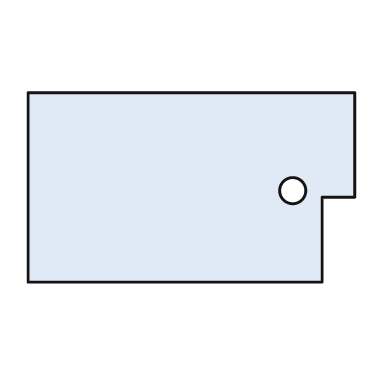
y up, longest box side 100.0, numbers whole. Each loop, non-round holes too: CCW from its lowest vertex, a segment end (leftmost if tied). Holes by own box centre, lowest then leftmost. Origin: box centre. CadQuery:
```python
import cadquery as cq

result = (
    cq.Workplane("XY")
    .moveTo(-50.0, -29.0)
    .lineTo(40.0, -29.0)
    .lineTo(40.0, -3.0)
    .lineTo(50.0, -3.0)
    .lineTo(50.0, 29.0)
    .lineTo(-50.0, 29.0)
    .close()
    .moveTo(31.0, -1.0)
    .circle(4.0)
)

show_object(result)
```